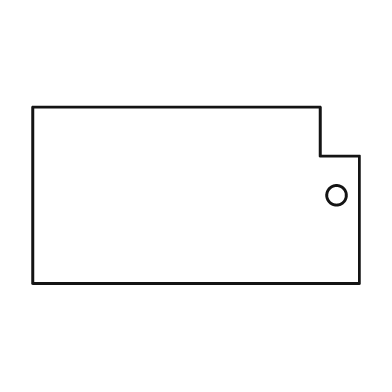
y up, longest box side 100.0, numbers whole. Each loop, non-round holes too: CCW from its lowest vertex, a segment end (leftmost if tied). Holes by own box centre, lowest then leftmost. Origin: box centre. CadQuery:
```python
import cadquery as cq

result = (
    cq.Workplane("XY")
    .moveTo(-50.0, -27.0)
    .lineTo(50.0, -27.0)
    .lineTo(50.0, 12.0)
    .lineTo(38.0, 12.0)
    .lineTo(38.0, 27.0)
    .lineTo(-50.0, 27.0)
    .close()
    .moveTo(43.0, 0.0)
    .circle(3.0)
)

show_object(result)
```